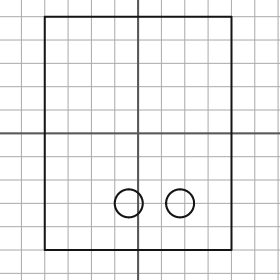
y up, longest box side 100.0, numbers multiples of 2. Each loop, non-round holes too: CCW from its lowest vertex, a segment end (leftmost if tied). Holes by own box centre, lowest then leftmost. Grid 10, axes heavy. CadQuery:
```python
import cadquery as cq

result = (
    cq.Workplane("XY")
    .moveTo(-40.0, -50.0)
    .lineTo(40.0, -50.0)
    .lineTo(40.0, 50.0)
    .lineTo(-40.0, 50.0)
    .close()
    .moveTo(-4.0, -30.0)
    .circle(6.0)
    .moveTo(18.0, -30.0)
    .circle(6.0)
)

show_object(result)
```